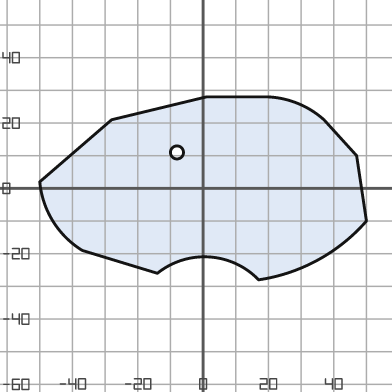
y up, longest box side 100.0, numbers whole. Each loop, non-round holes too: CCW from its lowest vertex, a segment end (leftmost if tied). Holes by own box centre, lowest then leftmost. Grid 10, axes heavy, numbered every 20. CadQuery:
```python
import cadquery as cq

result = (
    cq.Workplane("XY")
    .moveTo(17.0, -28.0)
    .threePointArc((35.0, -22.0), (50.0, -10.0))
    .lineTo(47.0, 10.0)
    .lineTo(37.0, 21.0)
    .threePointArc((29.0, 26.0), (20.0, 28.0))
    .lineTo(1.0, 28.0)
    .lineTo(-28.0, 21.0)
    .lineTo(-50.0, 2.0)
    .threePointArc((-46.0, -10.0), (-37.0, -19.0))
    .lineTo(-14.0, -26.0)
    .threePointArc((2.0, -21.0), (17.0, -28.0))
    .close()
    .moveTo(-8.0, 11.0)
    .circle(2.0)
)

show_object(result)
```